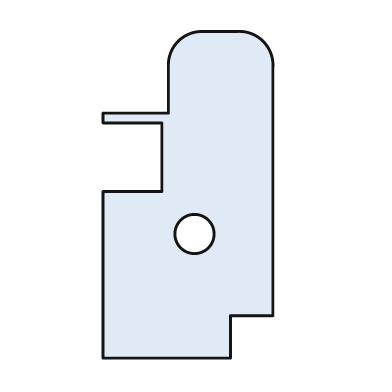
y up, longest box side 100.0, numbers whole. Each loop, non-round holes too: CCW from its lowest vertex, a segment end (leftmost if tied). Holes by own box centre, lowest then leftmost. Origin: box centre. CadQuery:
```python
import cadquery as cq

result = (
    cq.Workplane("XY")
    .moveTo(-26.0, -50.0)
    .lineTo(13.0, -50.0)
    .lineTo(13.0, -37.0)
    .lineTo(26.0, -37.0)
    .lineTo(26.0, 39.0)
    .threePointArc((23.0, 47.0), (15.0, 50.0))
    .lineTo(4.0, 50.0)
    .threePointArc((-3.0, 47.0), (-6.0, 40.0))
    .lineTo(-6.0, 25.0)
    .lineTo(-26.0, 25.0)
    .lineTo(-26.0, 22.0)
    .lineTo(-8.0, 22.0)
    .lineTo(-8.0, 1.0)
    .lineTo(-26.0, 1.0)
    .close()
    .moveTo(2.0, -12.0)
    .circle(6.0)
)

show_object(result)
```